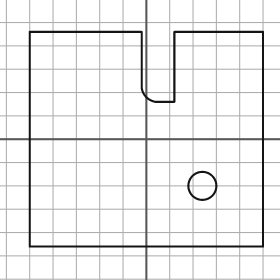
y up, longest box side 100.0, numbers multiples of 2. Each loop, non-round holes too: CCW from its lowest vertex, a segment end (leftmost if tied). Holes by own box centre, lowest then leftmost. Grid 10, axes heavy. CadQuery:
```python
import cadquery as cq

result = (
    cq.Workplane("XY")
    .moveTo(-50.0, -46.0)
    .lineTo(50.0, -46.0)
    .lineTo(50.0, 46.0)
    .lineTo(12.0, 46.0)
    .lineTo(12.0, 16.0)
    .lineTo(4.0, 16.0)
    .threePointArc((0.0, 18.0), (-2.0, 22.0))
    .lineTo(-2.0, 46.0)
    .lineTo(-50.0, 46.0)
    .close()
    .moveTo(24.0, -20.0)
    .circle(6.0)
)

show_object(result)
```